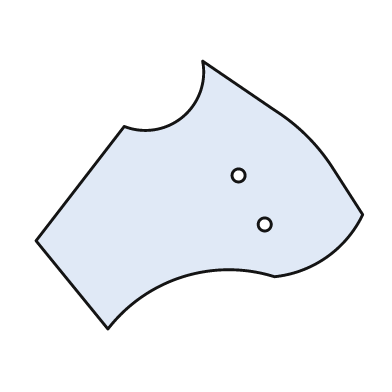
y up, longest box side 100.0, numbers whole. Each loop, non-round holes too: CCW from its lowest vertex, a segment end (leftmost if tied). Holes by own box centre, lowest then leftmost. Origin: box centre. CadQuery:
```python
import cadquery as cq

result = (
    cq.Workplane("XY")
    .moveTo(-28.0, -41.0)
    .threePointArc((-5.0, -25.0), (23.0, -25.0))
    .threePointArc((39.0, -19.0), (50.0, -6.0))
    .lineTo(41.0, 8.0)
    .threePointArc((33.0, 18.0), (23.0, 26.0))
    .lineTo(1.0, 41.0)
    .threePointArc((-5.0, 24.0), (-23.0, 21.0))
    .lineTo(-50.0, -14.0)
    .close()
    .moveTo(20.0, -9.0)
    .circle(2.0)
    .moveTo(12.0, 6.0)
    .circle(2.0)
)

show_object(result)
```